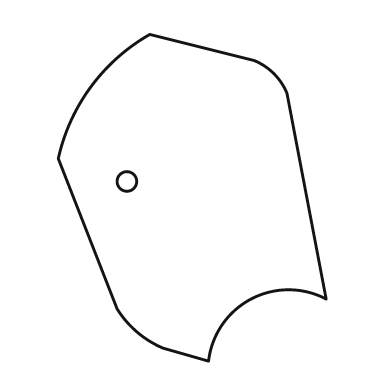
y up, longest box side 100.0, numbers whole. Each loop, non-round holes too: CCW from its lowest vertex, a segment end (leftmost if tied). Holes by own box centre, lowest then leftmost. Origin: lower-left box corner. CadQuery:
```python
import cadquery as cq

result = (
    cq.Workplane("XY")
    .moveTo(46.0, 0.0)
    .threePointArc((59.0, 19.0), (82.0, 19.0))
    .lineTo(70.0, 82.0)
    .threePointArc((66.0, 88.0), (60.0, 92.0))
    .lineTo(28.0, 100.0)
    .threePointArc((10.0, 84.0), (0.0, 62.0))
    .lineTo(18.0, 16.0)
    .threePointArc((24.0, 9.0), (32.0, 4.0))
    .close()
    .moveTo(21.0, 55.0)
    .circle(3.0)
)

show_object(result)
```